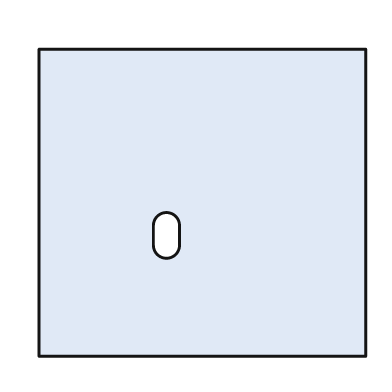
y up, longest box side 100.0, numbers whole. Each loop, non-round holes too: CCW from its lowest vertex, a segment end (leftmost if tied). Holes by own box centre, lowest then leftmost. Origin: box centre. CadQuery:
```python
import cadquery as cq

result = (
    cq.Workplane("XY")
    .moveTo(-50.0, -47.0)
    .lineTo(50.0, -47.0)
    .lineTo(50.0, 47.0)
    .lineTo(-50.0, 47.0)
    .close()
    .moveTo(-15.0, -13.0)
    .threePointArc((-11.0, -17.0), (-7.0, -13.0))
    .lineTo(-7.0, -7.0)
    .threePointArc((-11.0, -3.0), (-15.0, -7.0))
    .close()
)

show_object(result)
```